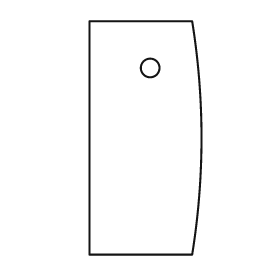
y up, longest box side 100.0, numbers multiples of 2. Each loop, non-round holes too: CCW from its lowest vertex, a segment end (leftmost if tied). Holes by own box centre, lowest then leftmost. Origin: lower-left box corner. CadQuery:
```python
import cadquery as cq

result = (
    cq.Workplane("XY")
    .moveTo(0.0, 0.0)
    .lineTo(44.0, 0.0)
    .threePointArc((48.0, 50.0), (44.0, 100.0))
    .lineTo(0.0, 100.0)
    .close()
    .moveTo(26.0, 80.0)
    .circle(4.0)
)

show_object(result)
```